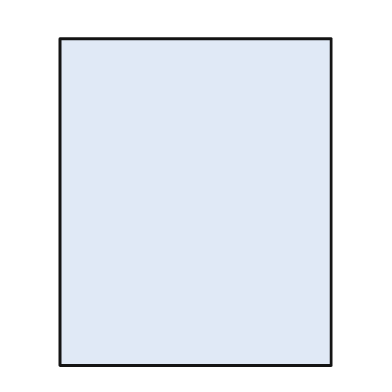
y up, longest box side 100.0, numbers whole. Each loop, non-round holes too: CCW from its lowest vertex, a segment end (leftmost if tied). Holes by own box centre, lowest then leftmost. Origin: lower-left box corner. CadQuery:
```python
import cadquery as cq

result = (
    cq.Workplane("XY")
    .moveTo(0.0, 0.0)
    .lineTo(83.0, 0.0)
    .lineTo(83.0, 100.0)
    .lineTo(0.0, 100.0)
    .close()
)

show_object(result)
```